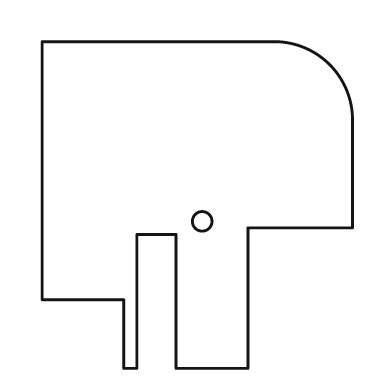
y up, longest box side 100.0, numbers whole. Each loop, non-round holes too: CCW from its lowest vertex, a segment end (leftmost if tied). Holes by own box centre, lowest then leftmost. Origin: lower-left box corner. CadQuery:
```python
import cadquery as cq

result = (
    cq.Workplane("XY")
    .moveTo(25.0, 0.0)
    .lineTo(29.0, 0.0)
    .lineTo(29.0, 41.0)
    .lineTo(41.0, 41.0)
    .lineTo(41.0, 0.0)
    .lineTo(63.0, 0.0)
    .lineTo(63.0, 43.0)
    .lineTo(95.0, 43.0)
    .lineTo(95.0, 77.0)
    .threePointArc((88.0, 93.0), (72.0, 100.0))
    .lineTo(0.0, 100.0)
    .lineTo(0.0, 21.0)
    .lineTo(25.0, 21.0)
    .close()
    .moveTo(49.0, 45.0)
    .circle(3.0)
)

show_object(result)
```